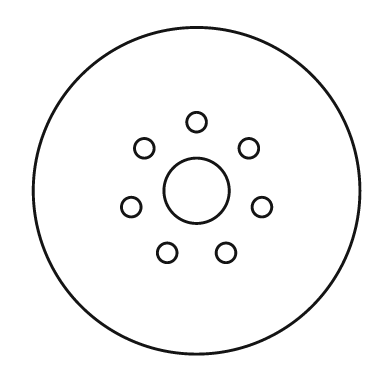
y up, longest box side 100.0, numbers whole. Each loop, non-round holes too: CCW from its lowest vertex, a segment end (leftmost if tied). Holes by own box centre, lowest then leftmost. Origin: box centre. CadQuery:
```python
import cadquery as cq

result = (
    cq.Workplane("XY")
    .moveTo(0.0, 0.0)
    .circle(50.0)
    .moveTo(-9.0, -19.0)
    .circle(3.0)
    .moveTo(9.0, -19.0)
    .circle(3.0)
    .moveTo(-20.0, -5.0)
    .circle(3.0)
    .moveTo(20.0, -5.0)
    .circle(3.0)
    .moveTo(0.0, 0.0)
    .circle(10.0)
    .moveTo(-16.0, 13.0)
    .circle(3.0)
    .moveTo(16.0, 13.0)
    .circle(3.0)
    .moveTo(0.0, 21.0)
    .circle(3.0)
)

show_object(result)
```